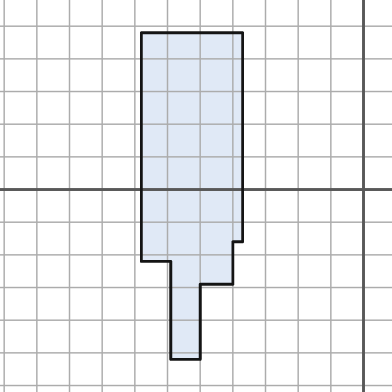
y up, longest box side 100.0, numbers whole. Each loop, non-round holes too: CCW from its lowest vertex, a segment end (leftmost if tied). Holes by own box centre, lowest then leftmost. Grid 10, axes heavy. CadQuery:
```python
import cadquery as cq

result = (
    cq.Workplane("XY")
    .moveTo(-59.0, -52.0)
    .lineTo(-50.0, -52.0)
    .lineTo(-50.0, -29.0)
    .lineTo(-40.0, -29.0)
    .lineTo(-40.0, -16.0)
    .lineTo(-37.0, -16.0)
    .lineTo(-37.0, 48.0)
    .lineTo(-68.0, 48.0)
    .lineTo(-68.0, -22.0)
    .lineTo(-59.0, -22.0)
    .close()
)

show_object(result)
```